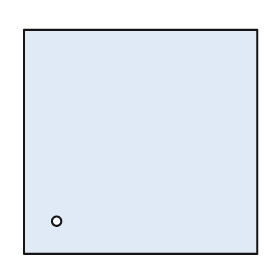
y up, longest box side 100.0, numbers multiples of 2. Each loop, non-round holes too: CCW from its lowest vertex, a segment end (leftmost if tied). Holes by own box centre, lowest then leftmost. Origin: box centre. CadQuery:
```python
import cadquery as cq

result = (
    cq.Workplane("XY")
    .moveTo(-50.0, -48.0)
    .lineTo(50.0, -48.0)
    .lineTo(50.0, 48.0)
    .lineTo(-50.0, 48.0)
    .close()
    .moveTo(-36.0, -34.0)
    .circle(2.0)
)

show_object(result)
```